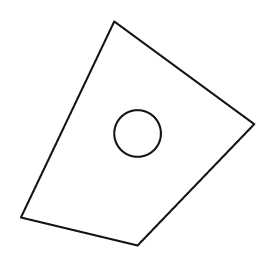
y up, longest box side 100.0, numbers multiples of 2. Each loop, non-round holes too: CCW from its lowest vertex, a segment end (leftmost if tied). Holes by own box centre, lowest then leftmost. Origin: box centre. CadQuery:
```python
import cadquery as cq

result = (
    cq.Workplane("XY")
    .moveTo(0.0, -48.0)
    .lineTo(50.0, 4.0)
    .lineTo(-10.0, 48.0)
    .lineTo(-50.0, -36.0)
    .close()
    .moveTo(0.0, 0.0)
    .circle(10.0)
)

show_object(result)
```